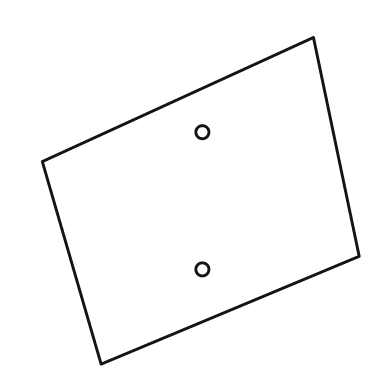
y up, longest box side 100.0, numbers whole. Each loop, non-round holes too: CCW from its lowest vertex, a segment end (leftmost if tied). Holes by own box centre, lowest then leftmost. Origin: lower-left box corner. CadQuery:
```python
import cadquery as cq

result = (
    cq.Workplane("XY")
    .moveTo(18.0, 0.0)
    .lineTo(97.0, 33.0)
    .lineTo(83.0, 100.0)
    .lineTo(0.0, 62.0)
    .close()
    .moveTo(49.0, 29.0)
    .circle(2.0)
    .moveTo(49.0, 71.0)
    .circle(2.0)
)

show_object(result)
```